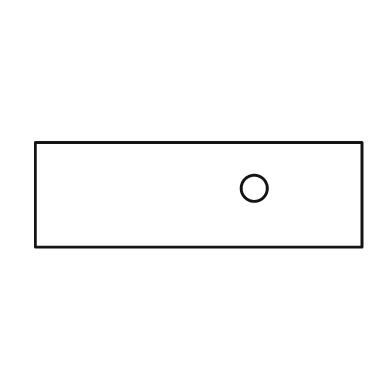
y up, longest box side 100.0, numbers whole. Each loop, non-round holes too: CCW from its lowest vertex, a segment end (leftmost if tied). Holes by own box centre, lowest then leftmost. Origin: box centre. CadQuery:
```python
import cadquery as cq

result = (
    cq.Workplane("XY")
    .moveTo(-50.0, -16.0)
    .lineTo(50.0, -16.0)
    .lineTo(50.0, 16.0)
    .lineTo(-50.0, 16.0)
    .close()
    .moveTo(17.0, 2.0)
    .circle(4.0)
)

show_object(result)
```